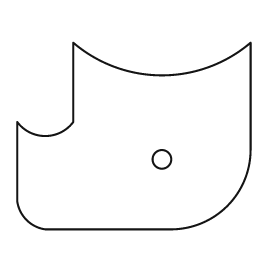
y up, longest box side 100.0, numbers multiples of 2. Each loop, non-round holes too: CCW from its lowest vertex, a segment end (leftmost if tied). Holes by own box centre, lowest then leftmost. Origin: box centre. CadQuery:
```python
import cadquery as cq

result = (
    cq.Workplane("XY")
    .moveTo(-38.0, -40.0)
    .lineTo(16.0, -40.0)
    .threePointArc((40.0, -30.0), (50.0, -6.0))
    .lineTo(50.0, 40.0)
    .threePointArc((12.0, 26.0), (-26.0, 40.0))
    .lineTo(-26.0, 6.0)
    .threePointArc((-38.0, 0.0), (-50.0, 6.0))
    .lineTo(-50.0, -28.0)
    .threePointArc((-46.0, -36.0), (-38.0, -40.0))
    .close()
    .moveTo(12.0, -10.0)
    .circle(4.0)
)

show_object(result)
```